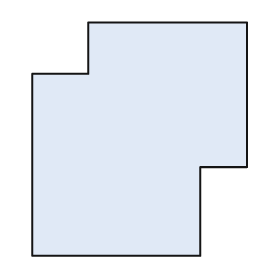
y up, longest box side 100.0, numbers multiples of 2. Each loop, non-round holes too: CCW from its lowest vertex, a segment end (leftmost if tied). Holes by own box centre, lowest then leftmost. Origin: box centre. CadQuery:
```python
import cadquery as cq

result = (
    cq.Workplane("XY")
    .moveTo(-46.0, -50.0)
    .lineTo(26.0, -50.0)
    .lineTo(26.0, -12.0)
    .lineTo(46.0, -12.0)
    .lineTo(46.0, 50.0)
    .lineTo(-22.0, 50.0)
    .lineTo(-22.0, 28.0)
    .lineTo(-46.0, 28.0)
    .close()
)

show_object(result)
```